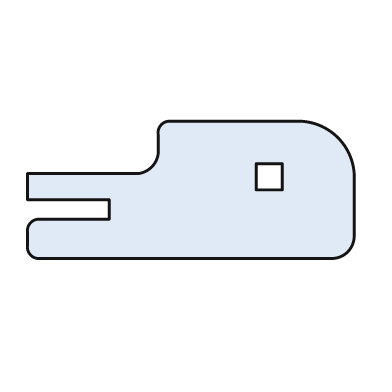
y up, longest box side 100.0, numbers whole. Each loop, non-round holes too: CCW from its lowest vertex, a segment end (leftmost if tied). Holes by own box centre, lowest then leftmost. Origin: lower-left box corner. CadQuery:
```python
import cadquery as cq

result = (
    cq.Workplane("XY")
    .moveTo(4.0, 0.0)
    .lineTo(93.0, 0.0)
    .threePointArc((98.0, 2.0), (100.0, 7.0))
    .lineTo(100.0, 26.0)
    .threePointArc((95.0, 37.0), (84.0, 42.0))
    .lineTo(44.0, 42.0)
    .threePointArc((41.0, 41.0), (40.0, 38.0))
    .lineTo(40.0, 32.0)
    .threePointArc((38.0, 28.0), (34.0, 26.0))
    .lineTo(0.0, 26.0)
    .lineTo(0.0, 18.0)
    .lineTo(25.0, 18.0)
    .lineTo(25.0, 12.0)
    .lineTo(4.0, 12.0)
    .threePointArc((1.0, 11.0), (0.0, 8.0))
    .lineTo(0.0, 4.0)
    .threePointArc((1.0, 1.0), (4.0, 0.0))
    .close()
    .moveTo(70.0, 21.0)
    .lineTo(78.0, 21.0)
    .lineTo(78.0, 29.0)
    .lineTo(70.0, 29.0)
    .close()
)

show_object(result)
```